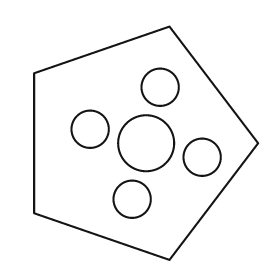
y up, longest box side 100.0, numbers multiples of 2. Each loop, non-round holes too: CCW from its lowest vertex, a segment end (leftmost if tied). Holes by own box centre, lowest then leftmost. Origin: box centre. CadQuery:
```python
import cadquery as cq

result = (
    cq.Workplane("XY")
    .moveTo(10.0, -50.0)
    .lineTo(48.0, 0.0)
    .lineTo(10.0, 50.0)
    .lineTo(-48.0, 30.0)
    .lineTo(-48.0, -30.0)
    .close()
    .moveTo(-6.0, -24.0)
    .circle(8.0)
    .moveTo(24.0, -6.0)
    .circle(8.0)
    .moveTo(0.0, 0.0)
    .circle(12.0)
    .moveTo(-24.0, 6.0)
    .circle(8.0)
    .moveTo(6.0, 24.0)
    .circle(8.0)
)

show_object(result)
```